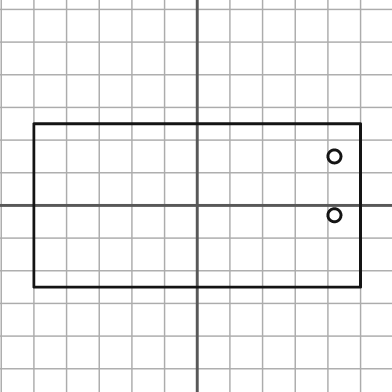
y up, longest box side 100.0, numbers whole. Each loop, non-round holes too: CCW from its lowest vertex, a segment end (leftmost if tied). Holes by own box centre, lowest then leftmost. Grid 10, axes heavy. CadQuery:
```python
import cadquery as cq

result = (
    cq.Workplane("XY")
    .moveTo(-50.0, -25.0)
    .lineTo(50.0, -25.0)
    .lineTo(50.0, 25.0)
    .lineTo(-50.0, 25.0)
    .close()
    .moveTo(42.0, -3.0)
    .circle(2.0)
    .moveTo(42.0, 15.0)
    .circle(2.0)
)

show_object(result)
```